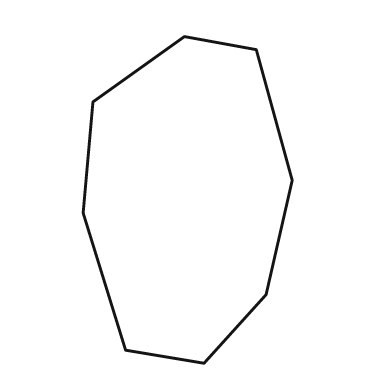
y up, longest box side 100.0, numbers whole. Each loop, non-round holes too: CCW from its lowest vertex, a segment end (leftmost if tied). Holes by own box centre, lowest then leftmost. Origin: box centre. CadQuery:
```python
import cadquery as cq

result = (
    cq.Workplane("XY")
    .moveTo(5.0, -50.0)
    .lineTo(24.0, -29.0)
    .lineTo(32.0, 6.0)
    .lineTo(21.0, 46.0)
    .lineTo(-1.0, 50.0)
    .lineTo(-29.0, 30.0)
    .lineTo(-32.0, -4.0)
    .lineTo(-19.0, -46.0)
    .close()
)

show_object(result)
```